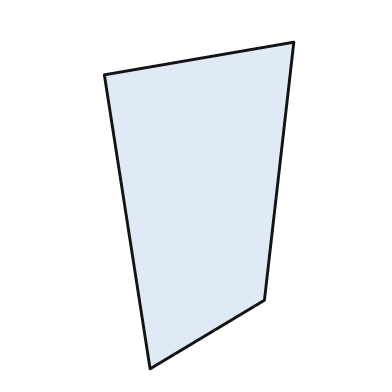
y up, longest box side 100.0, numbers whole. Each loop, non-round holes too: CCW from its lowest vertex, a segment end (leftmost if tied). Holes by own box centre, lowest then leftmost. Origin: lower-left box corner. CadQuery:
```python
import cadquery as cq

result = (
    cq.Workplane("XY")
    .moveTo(14.0, 0.0)
    .lineTo(49.0, 21.0)
    .lineTo(58.0, 100.0)
    .lineTo(0.0, 90.0)
    .close()
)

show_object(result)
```